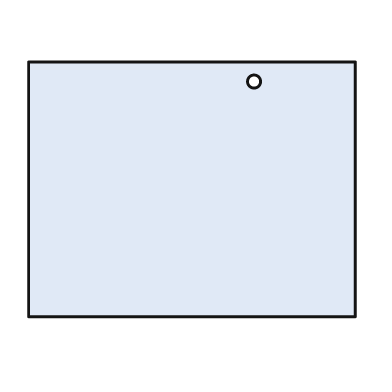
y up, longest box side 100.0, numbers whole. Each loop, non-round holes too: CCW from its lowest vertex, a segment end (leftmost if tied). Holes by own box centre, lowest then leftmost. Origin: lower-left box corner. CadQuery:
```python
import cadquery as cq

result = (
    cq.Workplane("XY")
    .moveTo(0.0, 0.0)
    .lineTo(100.0, 0.0)
    .lineTo(100.0, 78.0)
    .lineTo(0.0, 78.0)
    .close()
    .moveTo(69.0, 72.0)
    .circle(2.0)
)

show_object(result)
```